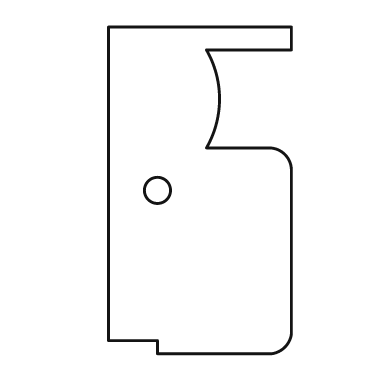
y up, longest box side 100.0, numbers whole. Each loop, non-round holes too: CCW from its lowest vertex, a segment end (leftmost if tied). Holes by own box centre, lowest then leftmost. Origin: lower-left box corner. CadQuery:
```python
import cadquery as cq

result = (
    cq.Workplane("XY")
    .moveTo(15.0, 0.0)
    .lineTo(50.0, 0.0)
    .threePointArc((54.0, 2.0), (56.0, 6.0))
    .lineTo(56.0, 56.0)
    .threePointArc((54.0, 61.0), (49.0, 63.0))
    .lineTo(30.0, 63.0)
    .threePointArc((34.0, 78.0), (30.0, 93.0))
    .lineTo(56.0, 93.0)
    .lineTo(56.0, 100.0)
    .lineTo(0.0, 100.0)
    .lineTo(0.0, 4.0)
    .lineTo(15.0, 4.0)
    .close()
    .moveTo(15.0, 50.0)
    .circle(4.0)
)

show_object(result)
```